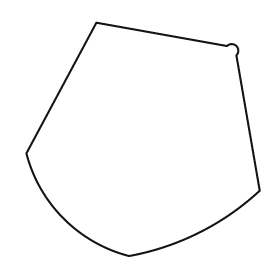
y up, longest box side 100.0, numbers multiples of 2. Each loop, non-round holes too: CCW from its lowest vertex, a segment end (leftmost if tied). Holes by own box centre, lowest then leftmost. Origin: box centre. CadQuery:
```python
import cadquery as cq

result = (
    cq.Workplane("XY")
    .moveTo(-6.0, -50.0)
    .threePointArc((24.0, -40.0), (50.0, -22.0))
    .lineTo(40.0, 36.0)
    .threePointArc((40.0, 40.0), (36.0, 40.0))
    .lineTo(-20.0, 50.0)
    .lineTo(-50.0, -6.0)
    .threePointArc((-34.0, -34.0), (-6.0, -50.0))
    .close()
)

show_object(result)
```